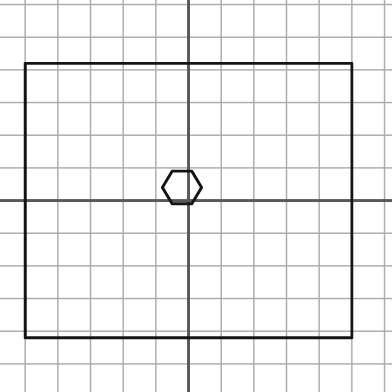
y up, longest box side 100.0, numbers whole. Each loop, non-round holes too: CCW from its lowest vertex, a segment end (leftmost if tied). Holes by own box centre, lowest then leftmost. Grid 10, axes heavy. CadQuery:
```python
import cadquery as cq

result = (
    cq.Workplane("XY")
    .moveTo(-50.0, -42.0)
    .lineTo(50.0, -42.0)
    .lineTo(50.0, 42.0)
    .lineTo(-50.0, 42.0)
    .close()
    .moveTo(-5.0, -1.0)
    .lineTo(1.0, -1.0)
    .lineTo(4.0, 4.0)
    .lineTo(1.0, 9.0)
    .lineTo(-5.0, 9.0)
    .lineTo(-8.0, 4.0)
    .close()
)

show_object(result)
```